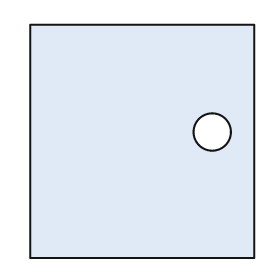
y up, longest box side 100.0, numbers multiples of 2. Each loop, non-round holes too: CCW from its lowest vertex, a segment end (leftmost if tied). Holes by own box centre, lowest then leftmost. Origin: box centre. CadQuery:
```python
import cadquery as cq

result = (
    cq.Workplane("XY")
    .moveTo(-48.0, -50.0)
    .lineTo(48.0, -50.0)
    .lineTo(48.0, 50.0)
    .lineTo(-48.0, 50.0)
    .close()
    .moveTo(30.0, 4.0)
    .circle(8.0)
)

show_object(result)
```